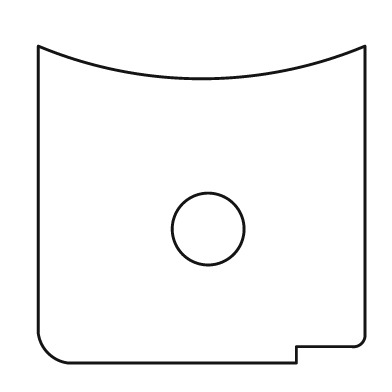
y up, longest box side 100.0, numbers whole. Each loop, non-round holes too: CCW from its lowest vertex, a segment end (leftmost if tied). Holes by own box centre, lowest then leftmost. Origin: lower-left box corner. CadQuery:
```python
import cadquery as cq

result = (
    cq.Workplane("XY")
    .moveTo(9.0, 0.0)
    .lineTo(79.0, 0.0)
    .lineTo(79.0, 5.0)
    .lineTo(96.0, 5.0)
    .threePointArc((99.0, 6.0), (100.0, 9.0))
    .lineTo(100.0, 97.0)
    .threePointArc((50.0, 87.0), (0.0, 97.0))
    .lineTo(0.0, 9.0)
    .threePointArc((3.0, 3.0), (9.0, 0.0))
    .close()
    .moveTo(52.0, 41.0)
    .circle(11.0)
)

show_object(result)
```